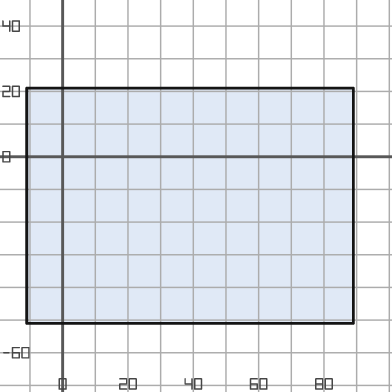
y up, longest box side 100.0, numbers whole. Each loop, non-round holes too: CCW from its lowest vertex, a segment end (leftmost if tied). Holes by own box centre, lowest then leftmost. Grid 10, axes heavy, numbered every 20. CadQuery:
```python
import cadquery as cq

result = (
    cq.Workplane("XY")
    .moveTo(-11.0, -51.0)
    .lineTo(89.0, -51.0)
    .lineTo(89.0, 21.0)
    .lineTo(-11.0, 21.0)
    .close()
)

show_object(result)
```